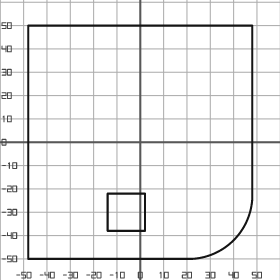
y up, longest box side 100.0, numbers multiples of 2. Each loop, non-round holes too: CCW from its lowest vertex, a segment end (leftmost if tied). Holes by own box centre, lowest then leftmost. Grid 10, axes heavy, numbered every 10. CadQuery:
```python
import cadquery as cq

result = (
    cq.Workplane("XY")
    .moveTo(-48.0, -50.0)
    .lineTo(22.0, -50.0)
    .threePointArc((40.0, -42.0), (48.0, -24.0))
    .lineTo(48.0, 50.0)
    .lineTo(-48.0, 50.0)
    .close()
    .moveTo(-14.0, -38.0)
    .lineTo(2.0, -38.0)
    .lineTo(2.0, -22.0)
    .lineTo(-14.0, -22.0)
    .close()
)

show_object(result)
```